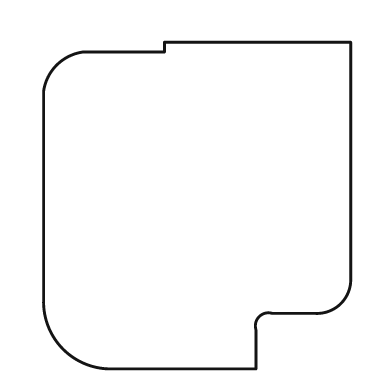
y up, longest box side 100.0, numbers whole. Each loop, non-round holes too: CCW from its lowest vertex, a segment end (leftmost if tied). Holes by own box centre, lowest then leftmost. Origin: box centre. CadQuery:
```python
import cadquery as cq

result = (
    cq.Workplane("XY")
    .moveTo(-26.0, -50.0)
    .lineTo(18.0, -50.0)
    .lineTo(18.0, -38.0)
    .threePointArc((19.0, -34.0), (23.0, -33.0))
    .lineTo(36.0, -33.0)
    .threePointArc((44.0, -30.0), (47.0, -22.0))
    .lineTo(47.0, 50.0)
    .lineTo(-10.0, 50.0)
    .lineTo(-10.0, 47.0)
    .lineTo(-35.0, 47.0)
    .threePointArc((-43.0, 43.0), (-47.0, 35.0))
    .lineTo(-47.0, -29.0)
    .threePointArc((-41.0, -44.0), (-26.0, -50.0))
    .close()
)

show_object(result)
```